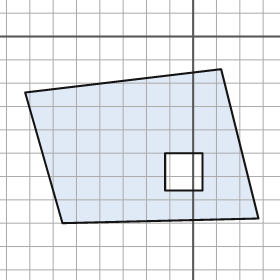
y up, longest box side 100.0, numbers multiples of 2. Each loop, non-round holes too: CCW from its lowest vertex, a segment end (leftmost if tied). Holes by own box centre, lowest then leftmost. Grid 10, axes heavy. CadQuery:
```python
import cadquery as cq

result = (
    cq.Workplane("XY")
    .moveTo(-56.0, -80.0)
    .lineTo(28.0, -78.0)
    .lineTo(12.0, -14.0)
    .lineTo(-72.0, -24.0)
    .close()
    .moveTo(-12.0, -66.0)
    .lineTo(4.0, -66.0)
    .lineTo(4.0, -50.0)
    .lineTo(-12.0, -50.0)
    .close()
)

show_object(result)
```